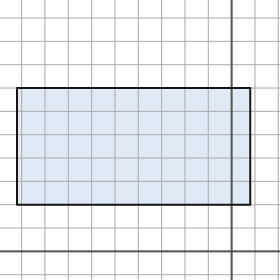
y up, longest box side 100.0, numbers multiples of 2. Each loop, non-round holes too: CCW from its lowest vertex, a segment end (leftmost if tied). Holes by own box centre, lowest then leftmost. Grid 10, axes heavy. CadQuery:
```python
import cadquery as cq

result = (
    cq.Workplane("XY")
    .moveTo(-92.0, 20.0)
    .lineTo(8.0, 20.0)
    .lineTo(8.0, 70.0)
    .lineTo(-92.0, 70.0)
    .close()
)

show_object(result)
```